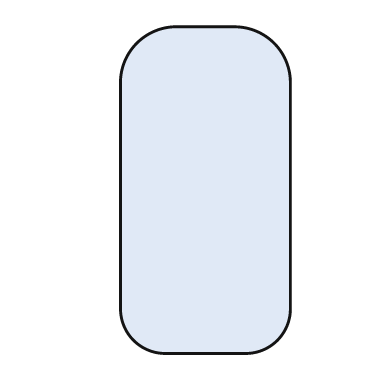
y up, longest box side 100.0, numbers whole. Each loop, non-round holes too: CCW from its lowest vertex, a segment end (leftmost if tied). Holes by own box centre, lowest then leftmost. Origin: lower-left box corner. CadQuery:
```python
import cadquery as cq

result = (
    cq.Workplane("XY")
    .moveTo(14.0, 0.0)
    .lineTo(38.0, 0.0)
    .threePointArc((48.0, 4.0), (52.0, 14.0))
    .lineTo(52.0, 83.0)
    .threePointArc((47.0, 95.0), (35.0, 100.0))
    .lineTo(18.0, 100.0)
    .threePointArc((5.0, 95.0), (0.0, 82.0))
    .lineTo(0.0, 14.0)
    .threePointArc((4.0, 4.0), (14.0, 0.0))
    .close()
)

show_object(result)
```